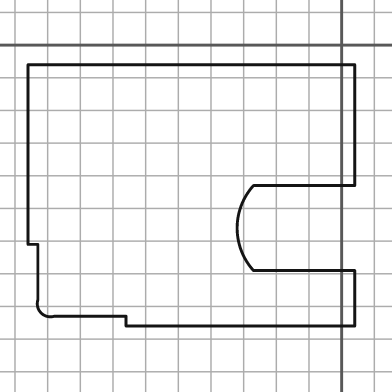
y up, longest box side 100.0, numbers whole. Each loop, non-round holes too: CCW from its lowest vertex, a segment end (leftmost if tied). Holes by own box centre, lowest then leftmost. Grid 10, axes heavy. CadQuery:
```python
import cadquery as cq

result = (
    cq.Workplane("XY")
    .moveTo(-66.0, -86.0)
    .lineTo(4.0, -86.0)
    .lineTo(4.0, -69.0)
    .lineTo(-27.0, -69.0)
    .threePointArc((-32.0, -56.0), (-27.0, -43.0))
    .lineTo(4.0, -43.0)
    .lineTo(4.0, -6.0)
    .lineTo(-96.0, -6.0)
    .lineTo(-96.0, -61.0)
    .lineTo(-93.0, -61.0)
    .lineTo(-93.0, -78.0)
    .threePointArc((-92.0, -82.0), (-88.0, -83.0))
    .lineTo(-66.0, -83.0)
    .close()
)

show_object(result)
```